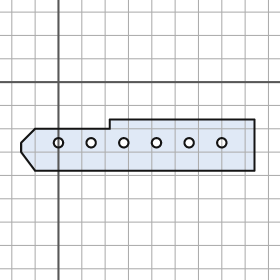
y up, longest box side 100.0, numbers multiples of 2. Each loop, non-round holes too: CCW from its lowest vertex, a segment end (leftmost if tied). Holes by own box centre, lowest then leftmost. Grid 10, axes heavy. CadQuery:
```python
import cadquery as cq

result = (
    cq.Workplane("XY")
    .moveTo(-10.0, -38.0)
    .lineTo(84.0, -38.0)
    .lineTo(84.0, -16.0)
    .lineTo(22.0, -16.0)
    .lineTo(22.0, -20.0)
    .lineTo(-10.0, -20.0)
    .lineTo(-16.0, -26.0)
    .lineTo(-16.0, -30.0)
    .close()
    .moveTo(0.0, -26.0)
    .circle(2.0)
    .moveTo(14.0, -26.0)
    .circle(2.0)
    .moveTo(28.0, -26.0)
    .circle(2.0)
    .moveTo(42.0, -26.0)
    .circle(2.0)
    .moveTo(56.0, -26.0)
    .circle(2.0)
    .moveTo(70.0, -26.0)
    .circle(2.0)
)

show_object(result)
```